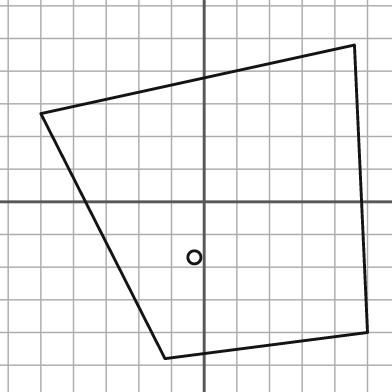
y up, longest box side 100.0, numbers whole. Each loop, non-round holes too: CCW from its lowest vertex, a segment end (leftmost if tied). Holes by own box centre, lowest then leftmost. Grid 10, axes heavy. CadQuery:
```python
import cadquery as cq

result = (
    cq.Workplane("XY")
    .moveTo(-12.0, -48.0)
    .lineTo(50.0, -40.0)
    .lineTo(46.0, 48.0)
    .lineTo(-50.0, 27.0)
    .close()
    .moveTo(-3.0, -17.0)
    .circle(2.0)
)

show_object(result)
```